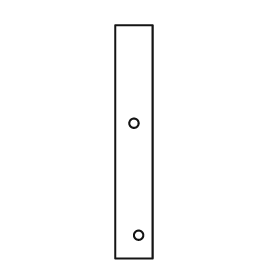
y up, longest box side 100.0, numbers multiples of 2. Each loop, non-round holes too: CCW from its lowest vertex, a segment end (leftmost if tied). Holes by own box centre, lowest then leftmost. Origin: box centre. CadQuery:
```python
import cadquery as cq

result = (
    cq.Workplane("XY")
    .moveTo(-8.0, -50.0)
    .lineTo(8.0, -50.0)
    .lineTo(8.0, 50.0)
    .lineTo(-8.0, 50.0)
    .close()
    .moveTo(2.0, -40.0)
    .circle(2.0)
    .moveTo(0.0, 8.0)
    .circle(2.0)
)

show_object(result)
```